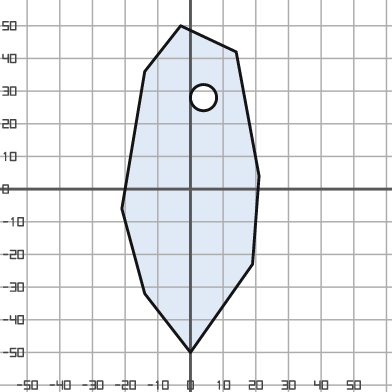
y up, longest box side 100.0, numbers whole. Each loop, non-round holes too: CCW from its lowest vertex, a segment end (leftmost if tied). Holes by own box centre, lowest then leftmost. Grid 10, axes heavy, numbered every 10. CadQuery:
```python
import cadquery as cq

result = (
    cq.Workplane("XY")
    .moveTo(0.0, -50.0)
    .lineTo(19.0, -23.0)
    .lineTo(21.0, 4.0)
    .lineTo(14.0, 42.0)
    .lineTo(-3.0, 50.0)
    .lineTo(-14.0, 36.0)
    .lineTo(-21.0, -6.0)
    .lineTo(-14.0, -32.0)
    .close()
    .moveTo(4.0, 28.0)
    .circle(4.0)
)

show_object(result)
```